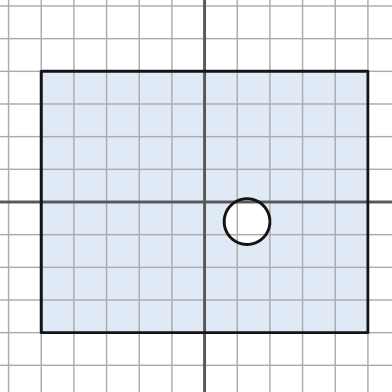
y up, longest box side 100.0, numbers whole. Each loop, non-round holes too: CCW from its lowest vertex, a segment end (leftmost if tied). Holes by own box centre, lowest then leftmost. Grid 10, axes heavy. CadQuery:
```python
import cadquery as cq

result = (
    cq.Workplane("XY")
    .moveTo(-50.0, -40.0)
    .lineTo(50.0, -40.0)
    .lineTo(50.0, 40.0)
    .lineTo(-50.0, 40.0)
    .close()
    .moveTo(13.0, -6.0)
    .circle(7.0)
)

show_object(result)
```